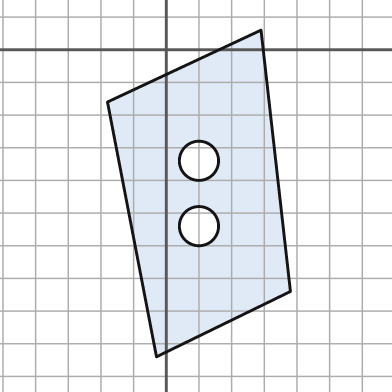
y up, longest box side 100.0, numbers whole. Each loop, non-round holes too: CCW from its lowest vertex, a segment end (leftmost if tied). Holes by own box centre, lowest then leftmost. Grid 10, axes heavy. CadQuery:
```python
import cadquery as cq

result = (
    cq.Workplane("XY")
    .moveTo(-3.0, -94.0)
    .lineTo(38.0, -74.0)
    .lineTo(29.0, 6.0)
    .lineTo(-18.0, -16.0)
    .close()
    .moveTo(10.0, -54.0)
    .circle(6.0)
    .moveTo(10.0, -34.0)
    .circle(6.0)
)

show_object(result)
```